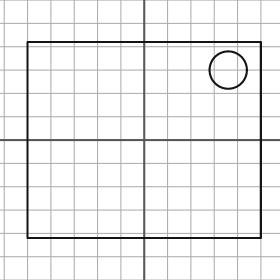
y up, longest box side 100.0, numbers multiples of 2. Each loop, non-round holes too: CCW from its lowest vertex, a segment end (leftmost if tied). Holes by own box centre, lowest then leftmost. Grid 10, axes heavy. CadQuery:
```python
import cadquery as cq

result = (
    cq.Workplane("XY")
    .moveTo(-50.0, -42.0)
    .lineTo(50.0, -42.0)
    .lineTo(50.0, 42.0)
    .lineTo(-50.0, 42.0)
    .close()
    .moveTo(36.0, 30.0)
    .circle(8.0)
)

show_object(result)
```